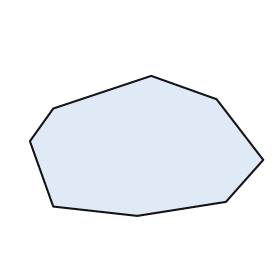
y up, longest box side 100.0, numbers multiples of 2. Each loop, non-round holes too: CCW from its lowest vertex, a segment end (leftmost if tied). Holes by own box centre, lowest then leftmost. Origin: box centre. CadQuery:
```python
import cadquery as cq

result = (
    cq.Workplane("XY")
    .moveTo(-4.0, -30.0)
    .lineTo(34.0, -24.0)
    .lineTo(50.0, -6.0)
    .lineTo(30.0, 20.0)
    .lineTo(2.0, 30.0)
    .lineTo(-40.0, 16.0)
    .lineTo(-50.0, 2.0)
    .lineTo(-40.0, -26.0)
    .close()
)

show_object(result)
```